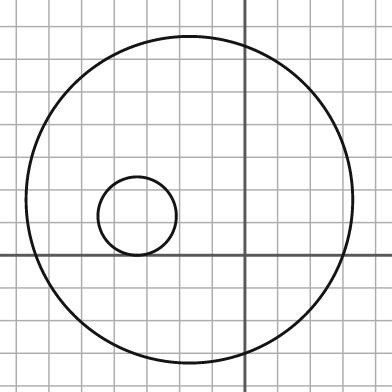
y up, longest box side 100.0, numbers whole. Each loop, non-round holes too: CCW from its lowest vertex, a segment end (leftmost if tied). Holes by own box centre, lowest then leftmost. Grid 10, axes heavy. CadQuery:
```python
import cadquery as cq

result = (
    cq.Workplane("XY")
    .moveTo(-17.0, 17.0)
    .circle(50.0)
    .moveTo(-33.0, 12.0)
    .circle(12.0)
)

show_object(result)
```